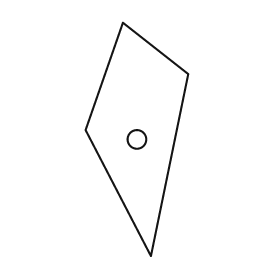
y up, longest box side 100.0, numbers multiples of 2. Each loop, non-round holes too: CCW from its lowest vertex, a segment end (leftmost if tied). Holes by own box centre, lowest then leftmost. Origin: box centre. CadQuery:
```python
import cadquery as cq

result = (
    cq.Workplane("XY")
    .moveTo(6.0, -50.0)
    .lineTo(22.0, 28.0)
    .lineTo(-6.0, 50.0)
    .lineTo(-22.0, 4.0)
    .close()
    .moveTo(0.0, 0.0)
    .circle(4.0)
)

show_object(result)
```